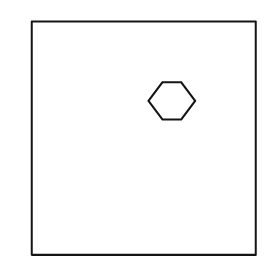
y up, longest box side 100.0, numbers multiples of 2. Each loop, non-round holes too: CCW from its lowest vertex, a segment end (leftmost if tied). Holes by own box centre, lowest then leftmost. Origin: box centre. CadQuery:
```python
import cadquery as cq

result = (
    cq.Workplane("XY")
    .moveTo(-48.0, -50.0)
    .lineTo(48.0, -50.0)
    .lineTo(48.0, 50.0)
    .lineTo(-48.0, 50.0)
    .close()
    .moveTo(8.0, 8.0)
    .lineTo(16.0, 8.0)
    .lineTo(22.0, 16.0)
    .lineTo(16.0, 24.0)
    .lineTo(8.0, 24.0)
    .lineTo(2.0, 16.0)
    .close()
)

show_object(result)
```